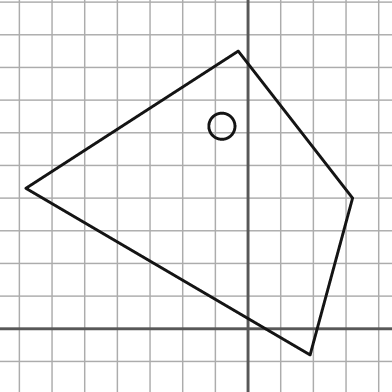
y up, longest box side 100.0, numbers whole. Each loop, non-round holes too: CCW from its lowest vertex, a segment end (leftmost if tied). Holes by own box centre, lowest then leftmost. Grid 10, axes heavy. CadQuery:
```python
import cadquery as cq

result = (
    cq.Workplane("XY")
    .moveTo(19.0, -8.0)
    .lineTo(32.0, 40.0)
    .lineTo(-3.0, 85.0)
    .lineTo(-68.0, 43.0)
    .close()
    .moveTo(-8.0, 62.0)
    .circle(4.0)
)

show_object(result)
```